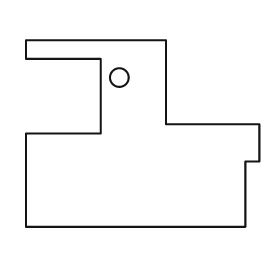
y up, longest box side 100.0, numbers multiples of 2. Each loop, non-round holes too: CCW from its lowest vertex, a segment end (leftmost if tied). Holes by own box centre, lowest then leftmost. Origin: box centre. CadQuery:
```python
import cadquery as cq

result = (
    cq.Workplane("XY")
    .moveTo(-50.0, -40.0)
    .lineTo(44.0, -40.0)
    .lineTo(44.0, -12.0)
    .lineTo(50.0, -12.0)
    .lineTo(50.0, 4.0)
    .lineTo(10.0, 4.0)
    .lineTo(10.0, 40.0)
    .lineTo(-50.0, 40.0)
    .lineTo(-50.0, 32.0)
    .lineTo(-18.0, 32.0)
    .lineTo(-18.0, 0.0)
    .lineTo(-50.0, 0.0)
    .close()
    .moveTo(-10.0, 24.0)
    .circle(4.0)
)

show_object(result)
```